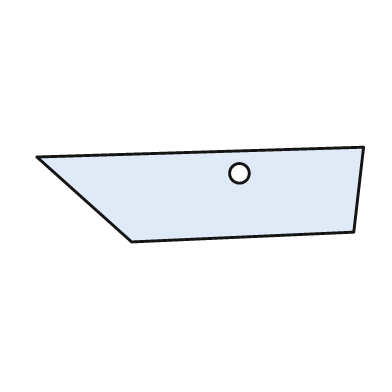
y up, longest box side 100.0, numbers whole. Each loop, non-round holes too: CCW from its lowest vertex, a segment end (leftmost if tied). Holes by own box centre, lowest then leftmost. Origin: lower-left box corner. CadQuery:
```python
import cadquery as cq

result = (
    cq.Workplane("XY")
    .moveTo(29.0, 0.0)
    .lineTo(97.0, 3.0)
    .lineTo(100.0, 29.0)
    .lineTo(0.0, 26.0)
    .close()
    .moveTo(62.0, 21.0)
    .circle(3.0)
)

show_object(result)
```